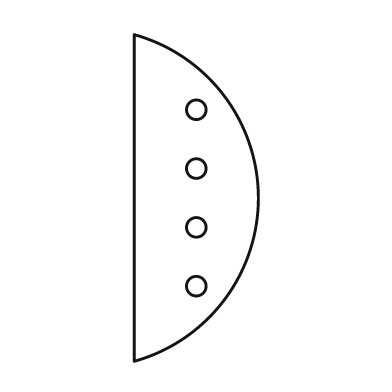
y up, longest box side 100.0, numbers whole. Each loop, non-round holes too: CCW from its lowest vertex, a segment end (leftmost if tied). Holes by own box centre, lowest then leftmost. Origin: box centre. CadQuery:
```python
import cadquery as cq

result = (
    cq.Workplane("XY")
    .moveTo(-19.0, -50.0)
    .threePointArc((19.0, 0.0), (-19.0, 50.0))
    .close()
    .moveTo(0.0, -27.0)
    .circle(3.0)
    .moveTo(0.0, -9.0)
    .circle(3.0)
    .moveTo(0.0, 9.0)
    .circle(3.0)
    .moveTo(0.0, 27.0)
    .circle(3.0)
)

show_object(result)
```